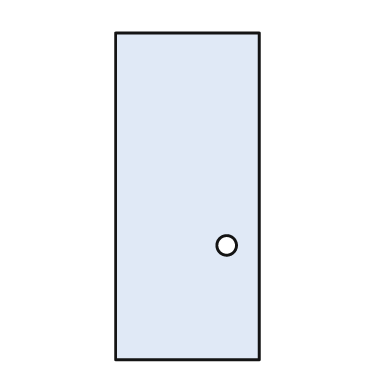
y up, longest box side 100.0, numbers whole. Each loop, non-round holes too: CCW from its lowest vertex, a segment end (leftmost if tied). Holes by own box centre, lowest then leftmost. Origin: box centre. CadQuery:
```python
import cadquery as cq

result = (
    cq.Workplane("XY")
    .moveTo(-22.0, -50.0)
    .lineTo(22.0, -50.0)
    .lineTo(22.0, 50.0)
    .lineTo(-22.0, 50.0)
    .close()
    .moveTo(12.0, -15.0)
    .circle(3.0)
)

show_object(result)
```